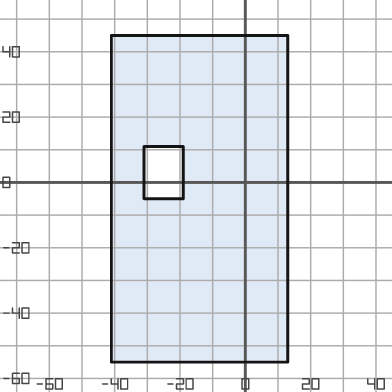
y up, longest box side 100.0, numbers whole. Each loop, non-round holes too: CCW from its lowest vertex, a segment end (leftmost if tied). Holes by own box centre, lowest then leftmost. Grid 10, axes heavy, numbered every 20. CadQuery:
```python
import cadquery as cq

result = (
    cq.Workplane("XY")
    .moveTo(-41.0, -55.0)
    .lineTo(13.0, -55.0)
    .lineTo(13.0, 45.0)
    .lineTo(-41.0, 45.0)
    .close()
    .moveTo(-31.0, -5.0)
    .lineTo(-19.0, -5.0)
    .lineTo(-19.0, 11.0)
    .lineTo(-31.0, 11.0)
    .close()
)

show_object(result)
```